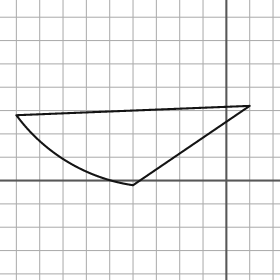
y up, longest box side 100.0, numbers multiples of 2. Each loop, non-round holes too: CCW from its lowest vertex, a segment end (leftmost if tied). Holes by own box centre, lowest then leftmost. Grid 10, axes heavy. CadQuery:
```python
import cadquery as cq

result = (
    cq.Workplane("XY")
    .moveTo(-40.0, -2.0)
    .lineTo(10.0, 32.0)
    .lineTo(-90.0, 28.0)
    .threePointArc((-68.0, 8.0), (-40.0, -2.0))
    .close()
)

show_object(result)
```